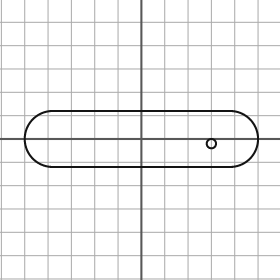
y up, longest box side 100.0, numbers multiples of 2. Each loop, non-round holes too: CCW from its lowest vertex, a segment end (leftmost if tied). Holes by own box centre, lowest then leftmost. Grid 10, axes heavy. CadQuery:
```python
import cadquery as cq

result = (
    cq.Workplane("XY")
    .moveTo(-38.0, -12.0)
    .lineTo(38.0, -12.0)
    .threePointArc((50.0, 0.0), (38.0, 12.0))
    .lineTo(-38.0, 12.0)
    .threePointArc((-50.0, 0.0), (-38.0, -12.0))
    .close()
    .moveTo(30.0, -2.0)
    .circle(2.0)
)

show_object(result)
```